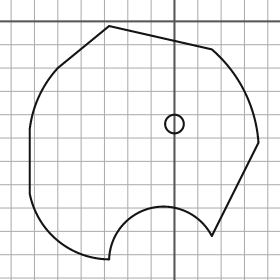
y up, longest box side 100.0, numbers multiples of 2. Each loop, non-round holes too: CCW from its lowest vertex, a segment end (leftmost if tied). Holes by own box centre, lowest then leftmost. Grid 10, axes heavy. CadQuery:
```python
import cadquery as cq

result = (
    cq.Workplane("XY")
    .moveTo(-28.0, -102.0)
    .threePointArc((-10.0, -80.0), (16.0, -92.0))
    .lineTo(36.0, -52.0)
    .threePointArc((30.0, -30.0), (16.0, -12.0))
    .lineTo(-28.0, -2.0)
    .lineTo(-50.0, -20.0)
    .threePointArc((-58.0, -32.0), (-62.0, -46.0))
    .lineTo(-62.0, -74.0)
    .threePointArc((-50.0, -94.0), (-28.0, -102.0))
    .close()
    .moveTo(0.0, -44.0)
    .circle(4.0)
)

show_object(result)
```